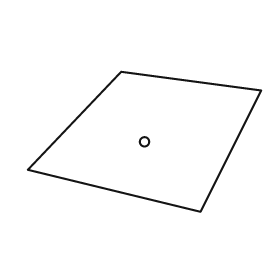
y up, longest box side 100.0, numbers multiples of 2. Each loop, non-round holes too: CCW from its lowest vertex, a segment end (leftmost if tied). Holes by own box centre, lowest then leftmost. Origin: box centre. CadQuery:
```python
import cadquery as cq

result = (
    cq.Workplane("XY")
    .moveTo(24.0, -30.0)
    .lineTo(50.0, 22.0)
    .lineTo(-10.0, 30.0)
    .lineTo(-50.0, -12.0)
    .close()
    .moveTo(0.0, 0.0)
    .circle(2.0)
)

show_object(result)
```